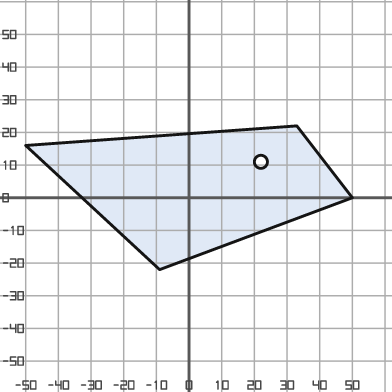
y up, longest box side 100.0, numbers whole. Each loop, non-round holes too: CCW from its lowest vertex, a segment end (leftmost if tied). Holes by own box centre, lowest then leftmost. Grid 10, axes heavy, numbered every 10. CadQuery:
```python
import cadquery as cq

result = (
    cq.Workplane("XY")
    .moveTo(-9.0, -22.0)
    .lineTo(50.0, 0.0)
    .lineTo(33.0, 22.0)
    .lineTo(-50.0, 16.0)
    .close()
    .moveTo(22.0, 11.0)
    .circle(2.0)
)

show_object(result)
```